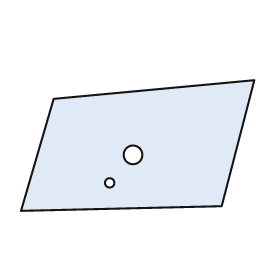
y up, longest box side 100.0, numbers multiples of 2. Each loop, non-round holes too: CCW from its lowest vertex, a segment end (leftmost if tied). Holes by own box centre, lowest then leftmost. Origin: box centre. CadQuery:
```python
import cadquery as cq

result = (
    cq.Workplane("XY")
    .moveTo(-50.0, -28.0)
    .lineTo(36.0, -26.0)
    .lineTo(50.0, 28.0)
    .lineTo(-36.0, 20.0)
    .close()
    .moveTo(-12.0, -16.0)
    .circle(2.0)
    .moveTo(-2.0, -4.0)
    .circle(4.0)
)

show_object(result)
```